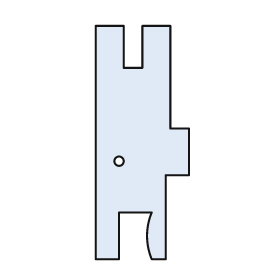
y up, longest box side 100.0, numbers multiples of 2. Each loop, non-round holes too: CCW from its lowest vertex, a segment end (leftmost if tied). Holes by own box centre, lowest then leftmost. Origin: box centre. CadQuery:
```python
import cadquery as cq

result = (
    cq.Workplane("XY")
    .moveTo(-20.0, -50.0)
    .lineTo(-10.0, -50.0)
    .lineTo(-10.0, -30.0)
    .lineTo(4.0, -30.0)
    .threePointArc((2.0, -40.0), (4.0, -50.0))
    .lineTo(10.0, -50.0)
    .lineTo(10.0, -14.0)
    .lineTo(20.0, -14.0)
    .lineTo(20.0, 6.0)
    .lineTo(12.0, 6.0)
    .lineTo(12.0, 50.0)
    .lineTo(0.0, 50.0)
    .lineTo(0.0, 32.0)
    .lineTo(-8.0, 32.0)
    .lineTo(-8.0, 50.0)
    .lineTo(-20.0, 50.0)
    .close()
    .moveTo(-10.0, -8.0)
    .circle(2.0)
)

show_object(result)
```